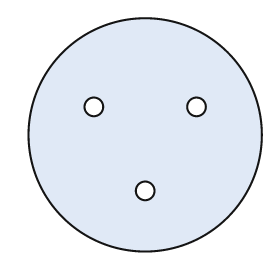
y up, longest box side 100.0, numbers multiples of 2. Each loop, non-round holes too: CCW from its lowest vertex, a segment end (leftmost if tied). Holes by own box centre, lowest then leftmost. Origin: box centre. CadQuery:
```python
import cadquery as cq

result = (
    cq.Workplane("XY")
    .moveTo(0.0, 0.0)
    .circle(50.0)
    .moveTo(0.0, -24.0)
    .circle(4.0)
    .moveTo(-22.0, 12.0)
    .circle(4.0)
    .moveTo(22.0, 12.0)
    .circle(4.0)
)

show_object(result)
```